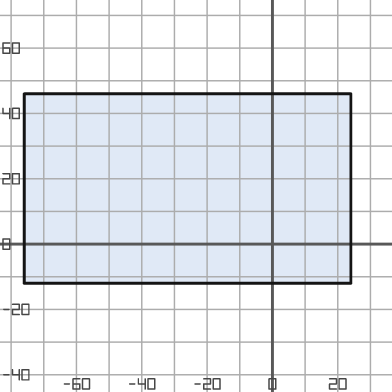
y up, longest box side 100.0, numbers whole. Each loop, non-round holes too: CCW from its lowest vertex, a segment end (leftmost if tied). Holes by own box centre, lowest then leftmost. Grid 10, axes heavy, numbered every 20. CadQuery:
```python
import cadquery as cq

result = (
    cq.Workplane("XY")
    .moveTo(-76.0, -12.0)
    .lineTo(24.0, -12.0)
    .lineTo(24.0, 46.0)
    .lineTo(-76.0, 46.0)
    .close()
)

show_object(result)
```